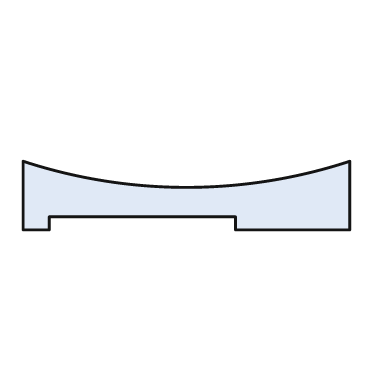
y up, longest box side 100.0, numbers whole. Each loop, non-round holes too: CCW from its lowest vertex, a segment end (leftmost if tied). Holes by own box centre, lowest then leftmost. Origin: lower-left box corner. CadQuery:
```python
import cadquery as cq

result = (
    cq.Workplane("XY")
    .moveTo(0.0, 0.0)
    .lineTo(8.0, 0.0)
    .lineTo(8.0, 4.0)
    .lineTo(65.0, 4.0)
    .lineTo(65.0, 0.0)
    .lineTo(100.0, 0.0)
    .lineTo(100.0, 21.0)
    .threePointArc((50.0, 13.0), (0.0, 21.0))
    .close()
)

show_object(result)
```